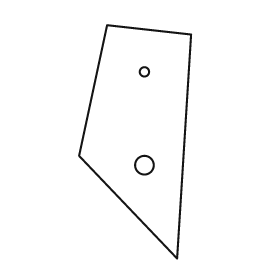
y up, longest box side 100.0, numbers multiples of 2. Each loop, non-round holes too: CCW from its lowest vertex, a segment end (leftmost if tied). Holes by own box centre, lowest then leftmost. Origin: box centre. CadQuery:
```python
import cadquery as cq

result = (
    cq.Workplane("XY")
    .moveTo(18.0, -50.0)
    .lineTo(24.0, 46.0)
    .lineTo(-12.0, 50.0)
    .lineTo(-24.0, -6.0)
    .close()
    .moveTo(4.0, -10.0)
    .circle(4.0)
    .moveTo(4.0, 30.0)
    .circle(2.0)
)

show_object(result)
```